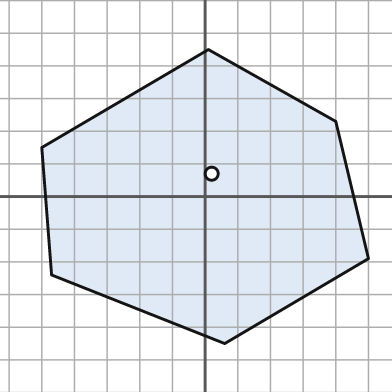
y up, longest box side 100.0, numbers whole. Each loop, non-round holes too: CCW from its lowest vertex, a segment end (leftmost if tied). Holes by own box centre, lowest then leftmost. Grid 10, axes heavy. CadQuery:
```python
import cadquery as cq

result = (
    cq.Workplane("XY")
    .moveTo(6.0, -45.0)
    .lineTo(50.0, -19.0)
    .lineTo(40.0, 23.0)
    .lineTo(1.0, 45.0)
    .lineTo(-50.0, 15.0)
    .lineTo(-47.0, -24.0)
    .close()
    .moveTo(2.0, 7.0)
    .circle(2.0)
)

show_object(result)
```